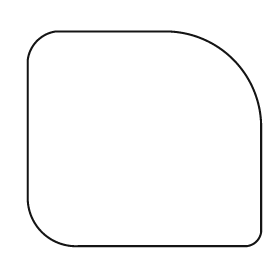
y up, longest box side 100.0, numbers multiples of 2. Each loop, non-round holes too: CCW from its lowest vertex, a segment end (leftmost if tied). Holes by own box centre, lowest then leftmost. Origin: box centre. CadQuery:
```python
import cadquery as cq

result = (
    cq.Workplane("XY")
    .moveTo(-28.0, -46.0)
    .lineTo(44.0, -46.0)
    .threePointArc((48.0, -44.0), (50.0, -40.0))
    .lineTo(50.0, 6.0)
    .threePointArc((38.0, 34.0), (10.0, 46.0))
    .lineTo(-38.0, 46.0)
    .threePointArc((-46.0, 42.0), (-50.0, 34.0))
    .lineTo(-50.0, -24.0)
    .threePointArc((-44.0, -40.0), (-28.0, -46.0))
    .close()
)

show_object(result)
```